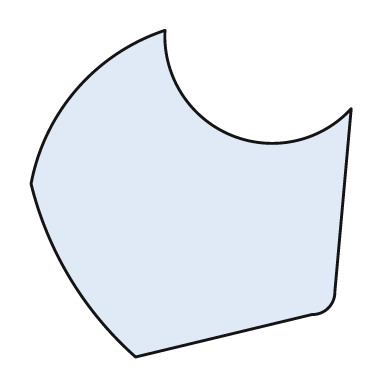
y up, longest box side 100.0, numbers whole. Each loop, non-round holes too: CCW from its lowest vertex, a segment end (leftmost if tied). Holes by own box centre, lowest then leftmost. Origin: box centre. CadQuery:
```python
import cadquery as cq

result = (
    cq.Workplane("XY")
    .moveTo(-17.0, -50.0)
    .lineTo(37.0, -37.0)
    .threePointArc((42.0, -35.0), (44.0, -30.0))
    .lineTo(49.0, 26.0)
    .threePointArc((12.0, 18.0), (-8.0, 50.0))
    .threePointArc((-35.0, 32.0), (-49.0, 3.0))
    .threePointArc((-37.0, -26.0), (-17.0, -50.0))
    .close()
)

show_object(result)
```